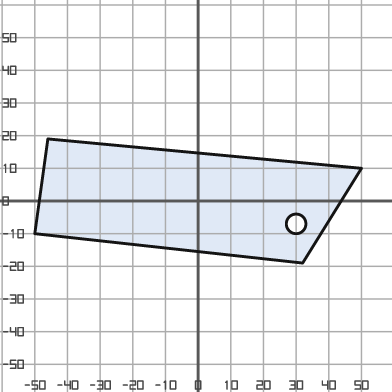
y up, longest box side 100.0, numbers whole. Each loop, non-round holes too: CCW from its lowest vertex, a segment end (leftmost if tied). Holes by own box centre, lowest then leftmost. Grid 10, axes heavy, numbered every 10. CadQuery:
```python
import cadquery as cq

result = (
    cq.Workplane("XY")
    .moveTo(32.0, -19.0)
    .lineTo(50.0, 10.0)
    .lineTo(-46.0, 19.0)
    .lineTo(-50.0, -10.0)
    .close()
    .moveTo(30.0, -7.0)
    .circle(3.0)
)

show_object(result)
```